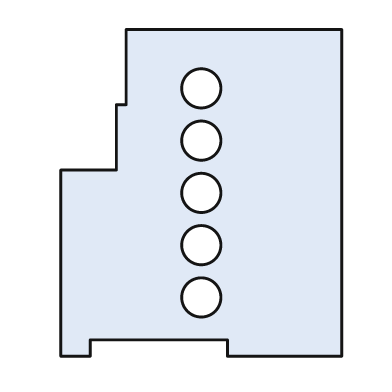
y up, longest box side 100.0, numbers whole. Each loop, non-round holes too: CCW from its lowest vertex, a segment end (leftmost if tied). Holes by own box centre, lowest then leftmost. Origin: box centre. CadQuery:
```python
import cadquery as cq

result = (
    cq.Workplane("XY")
    .moveTo(-43.0, -50.0)
    .lineTo(-34.0, -50.0)
    .lineTo(-34.0, -45.0)
    .lineTo(8.0, -45.0)
    .lineTo(8.0, -50.0)
    .lineTo(43.0, -50.0)
    .lineTo(43.0, 50.0)
    .lineTo(-23.0, 50.0)
    .lineTo(-23.0, 27.0)
    .lineTo(-26.0, 27.0)
    .lineTo(-26.0, 7.0)
    .lineTo(-43.0, 7.0)
    .close()
    .moveTo(0.0, -32.0)
    .circle(6.0)
    .moveTo(0.0, -16.0)
    .circle(6.0)
    .moveTo(0.0, 0.0)
    .circle(6.0)
    .moveTo(0.0, 16.0)
    .circle(6.0)
    .moveTo(0.0, 32.0)
    .circle(6.0)
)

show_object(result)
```